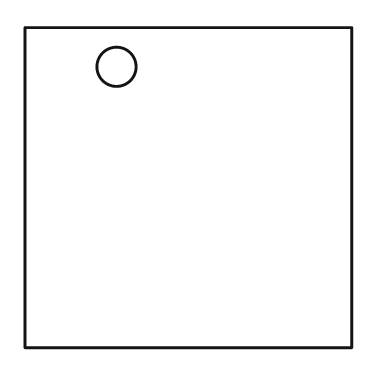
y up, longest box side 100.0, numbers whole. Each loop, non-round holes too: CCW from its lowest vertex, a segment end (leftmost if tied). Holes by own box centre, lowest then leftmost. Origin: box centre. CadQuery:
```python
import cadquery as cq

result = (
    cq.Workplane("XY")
    .moveTo(-50.0, -49.0)
    .lineTo(50.0, -49.0)
    .lineTo(50.0, 49.0)
    .lineTo(-50.0, 49.0)
    .close()
    .moveTo(-22.0, 37.0)
    .circle(6.0)
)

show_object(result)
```